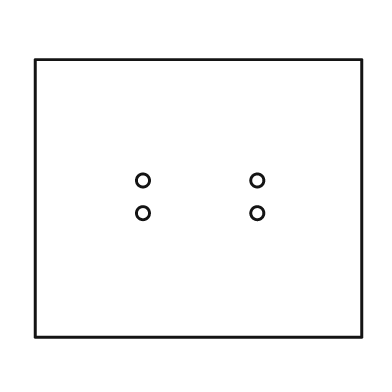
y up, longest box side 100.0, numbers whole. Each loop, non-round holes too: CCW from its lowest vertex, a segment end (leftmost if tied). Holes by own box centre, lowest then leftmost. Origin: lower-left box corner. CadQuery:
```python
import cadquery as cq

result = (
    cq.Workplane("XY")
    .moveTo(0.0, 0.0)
    .lineTo(100.0, 0.0)
    .lineTo(100.0, 85.0)
    .lineTo(0.0, 85.0)
    .close()
    .moveTo(33.0, 38.0)
    .circle(2.0)
    .moveTo(68.0, 38.0)
    .circle(2.0)
    .moveTo(33.0, 48.0)
    .circle(2.0)
    .moveTo(68.0, 48.0)
    .circle(2.0)
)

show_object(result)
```